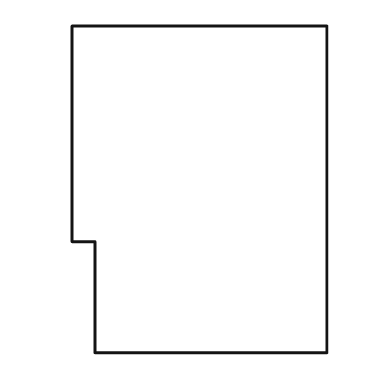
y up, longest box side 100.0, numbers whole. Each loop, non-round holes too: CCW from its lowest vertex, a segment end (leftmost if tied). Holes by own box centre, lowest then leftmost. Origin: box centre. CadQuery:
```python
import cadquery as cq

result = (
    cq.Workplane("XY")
    .moveTo(-32.0, -50.0)
    .lineTo(39.0, -50.0)
    .lineTo(39.0, 50.0)
    .lineTo(-39.0, 50.0)
    .lineTo(-39.0, -16.0)
    .lineTo(-32.0, -16.0)
    .close()
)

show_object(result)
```